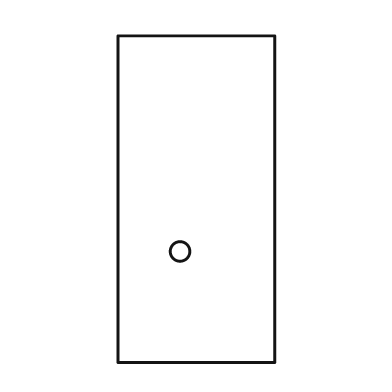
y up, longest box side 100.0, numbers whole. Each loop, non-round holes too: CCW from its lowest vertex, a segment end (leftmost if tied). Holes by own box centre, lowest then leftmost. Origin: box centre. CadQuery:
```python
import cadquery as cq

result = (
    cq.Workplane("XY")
    .moveTo(-24.0, -50.0)
    .lineTo(24.0, -50.0)
    .lineTo(24.0, 50.0)
    .lineTo(-24.0, 50.0)
    .close()
    .moveTo(-5.0, -16.0)
    .circle(3.0)
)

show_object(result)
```